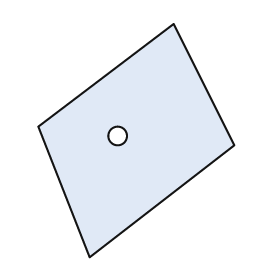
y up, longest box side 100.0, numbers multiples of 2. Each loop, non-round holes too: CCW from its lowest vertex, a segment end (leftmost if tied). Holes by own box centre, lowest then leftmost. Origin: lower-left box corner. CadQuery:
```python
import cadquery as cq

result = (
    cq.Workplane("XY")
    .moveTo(22.0, 0.0)
    .lineTo(84.0, 48.0)
    .lineTo(58.0, 100.0)
    .lineTo(0.0, 56.0)
    .close()
    .moveTo(34.0, 52.0)
    .circle(4.0)
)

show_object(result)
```